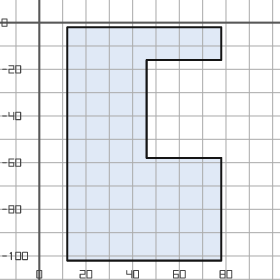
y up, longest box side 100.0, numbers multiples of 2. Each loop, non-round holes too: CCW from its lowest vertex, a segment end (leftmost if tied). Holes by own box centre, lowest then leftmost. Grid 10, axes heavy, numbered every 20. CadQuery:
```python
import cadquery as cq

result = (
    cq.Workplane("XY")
    .moveTo(12.0, -102.0)
    .lineTo(78.0, -102.0)
    .lineTo(78.0, -58.0)
    .lineTo(46.0, -58.0)
    .lineTo(46.0, -16.0)
    .lineTo(78.0, -16.0)
    .lineTo(78.0, -2.0)
    .lineTo(12.0, -2.0)
    .close()
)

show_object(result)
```